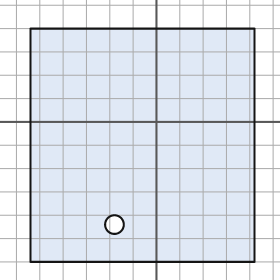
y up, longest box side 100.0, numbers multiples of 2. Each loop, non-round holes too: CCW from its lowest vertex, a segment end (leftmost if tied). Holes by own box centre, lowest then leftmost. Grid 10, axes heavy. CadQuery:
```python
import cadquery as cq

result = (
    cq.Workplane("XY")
    .moveTo(-54.0, -60.0)
    .lineTo(42.0, -60.0)
    .lineTo(42.0, 40.0)
    .lineTo(-54.0, 40.0)
    .close()
    .moveTo(-18.0, -44.0)
    .circle(4.0)
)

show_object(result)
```